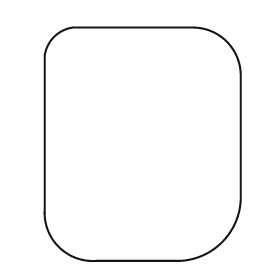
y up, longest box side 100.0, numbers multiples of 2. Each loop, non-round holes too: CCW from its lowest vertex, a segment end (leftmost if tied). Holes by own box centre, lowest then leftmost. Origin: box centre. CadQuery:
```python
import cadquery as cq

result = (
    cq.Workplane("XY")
    .moveTo(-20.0, -50.0)
    .lineTo(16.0, -50.0)
    .threePointArc((34.0, -42.0), (42.0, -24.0))
    .lineTo(42.0, 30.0)
    .threePointArc((36.0, 44.0), (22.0, 50.0))
    .lineTo(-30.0, 50.0)
    .threePointArc((-38.0, 46.0), (-42.0, 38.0))
    .lineTo(-42.0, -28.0)
    .threePointArc((-36.0, -44.0), (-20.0, -50.0))
    .close()
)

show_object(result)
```